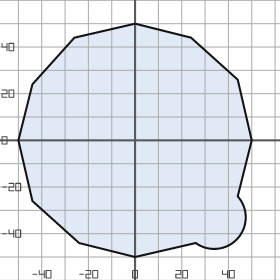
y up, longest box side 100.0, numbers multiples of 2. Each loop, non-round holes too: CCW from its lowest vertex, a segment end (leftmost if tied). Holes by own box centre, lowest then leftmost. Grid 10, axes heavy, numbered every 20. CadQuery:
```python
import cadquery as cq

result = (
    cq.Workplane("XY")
    .moveTo(0.0, -50.0)
    .lineTo(26.0, -44.0)
    .threePointArc((44.0, -42.0), (44.0, -24.0))
    .lineTo(50.0, 0.0)
    .lineTo(44.0, 26.0)
    .lineTo(24.0, 44.0)
    .lineTo(0.0, 50.0)
    .lineTo(-26.0, 44.0)
    .lineTo(-44.0, 24.0)
    .lineTo(-50.0, 0.0)
    .lineTo(-44.0, -26.0)
    .lineTo(-24.0, -44.0)
    .close()
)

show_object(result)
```